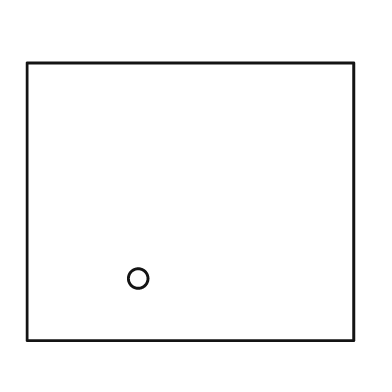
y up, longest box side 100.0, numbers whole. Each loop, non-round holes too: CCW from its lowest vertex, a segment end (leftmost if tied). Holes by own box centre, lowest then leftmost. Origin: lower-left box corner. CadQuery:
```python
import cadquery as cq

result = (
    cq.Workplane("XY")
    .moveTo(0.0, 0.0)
    .lineTo(100.0, 0.0)
    .lineTo(100.0, 85.0)
    .lineTo(0.0, 85.0)
    .close()
    .moveTo(34.0, 19.0)
    .circle(3.0)
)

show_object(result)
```